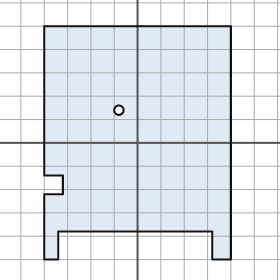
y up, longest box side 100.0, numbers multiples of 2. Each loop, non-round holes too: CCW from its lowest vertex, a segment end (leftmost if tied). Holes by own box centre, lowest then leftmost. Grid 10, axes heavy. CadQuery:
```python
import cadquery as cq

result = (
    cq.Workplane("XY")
    .moveTo(-40.0, -50.0)
    .lineTo(-34.0, -50.0)
    .lineTo(-34.0, -38.0)
    .lineTo(32.0, -38.0)
    .lineTo(32.0, -50.0)
    .lineTo(40.0, -50.0)
    .lineTo(40.0, 50.0)
    .lineTo(-40.0, 50.0)
    .lineTo(-40.0, -14.0)
    .lineTo(-32.0, -14.0)
    .lineTo(-32.0, -22.0)
    .lineTo(-40.0, -22.0)
    .close()
    .moveTo(-8.0, 14.0)
    .circle(2.0)
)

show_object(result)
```